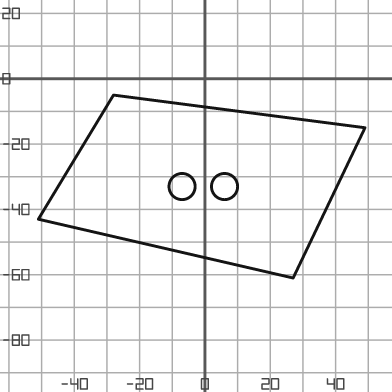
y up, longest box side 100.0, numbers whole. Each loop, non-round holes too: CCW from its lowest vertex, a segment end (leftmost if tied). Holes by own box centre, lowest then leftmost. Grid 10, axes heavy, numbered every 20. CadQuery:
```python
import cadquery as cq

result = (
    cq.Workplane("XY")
    .moveTo(27.0, -61.0)
    .lineTo(49.0, -15.0)
    .lineTo(-28.0, -5.0)
    .lineTo(-51.0, -43.0)
    .close()
    .moveTo(-7.0, -33.0)
    .circle(4.0)
    .moveTo(6.0, -33.0)
    .circle(4.0)
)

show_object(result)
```